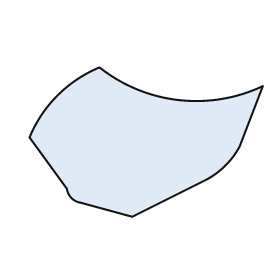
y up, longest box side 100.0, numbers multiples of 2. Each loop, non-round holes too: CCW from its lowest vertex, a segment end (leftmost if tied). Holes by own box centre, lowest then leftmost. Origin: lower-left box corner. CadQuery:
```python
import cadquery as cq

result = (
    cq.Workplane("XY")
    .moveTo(44.0, 0.0)
    .lineTo(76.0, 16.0)
    .threePointArc((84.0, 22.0), (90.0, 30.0))
    .lineTo(100.0, 56.0)
    .threePointArc((64.0, 50.0), (30.0, 64.0))
    .threePointArc((12.0, 52.0), (0.0, 34.0))
    .lineTo(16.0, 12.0)
    .threePointArc((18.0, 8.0), (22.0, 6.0))
    .close()
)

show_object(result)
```